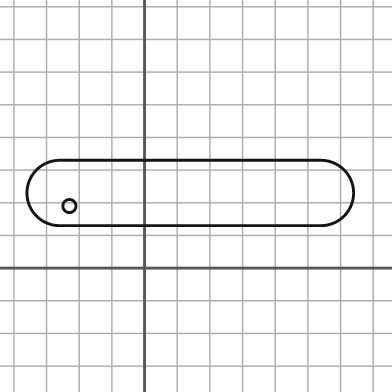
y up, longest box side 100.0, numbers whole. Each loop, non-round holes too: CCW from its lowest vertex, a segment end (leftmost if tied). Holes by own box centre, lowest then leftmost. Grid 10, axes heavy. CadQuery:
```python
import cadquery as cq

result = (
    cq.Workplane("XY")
    .moveTo(-26.0, 13.0)
    .lineTo(54.0, 13.0)
    .threePointArc((64.0, 23.0), (54.0, 33.0))
    .lineTo(-26.0, 33.0)
    .threePointArc((-36.0, 23.0), (-26.0, 13.0))
    .close()
    .moveTo(-23.0, 19.0)
    .circle(2.0)
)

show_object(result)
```